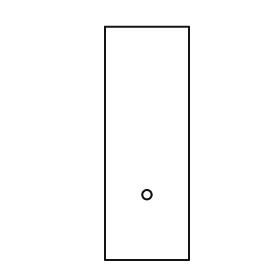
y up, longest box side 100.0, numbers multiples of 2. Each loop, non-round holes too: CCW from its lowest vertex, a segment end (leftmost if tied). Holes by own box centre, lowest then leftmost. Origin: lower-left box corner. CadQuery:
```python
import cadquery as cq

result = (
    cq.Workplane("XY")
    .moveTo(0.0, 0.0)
    .lineTo(36.0, 0.0)
    .lineTo(36.0, 100.0)
    .lineTo(0.0, 100.0)
    .close()
    .moveTo(18.0, 28.0)
    .circle(2.0)
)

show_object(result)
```